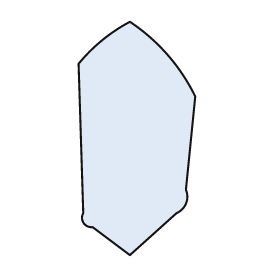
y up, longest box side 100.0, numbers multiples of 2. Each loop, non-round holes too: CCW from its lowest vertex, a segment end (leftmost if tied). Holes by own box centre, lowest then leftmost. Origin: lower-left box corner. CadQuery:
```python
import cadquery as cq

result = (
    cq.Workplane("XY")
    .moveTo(22.0, 0.0)
    .lineTo(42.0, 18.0)
    .threePointArc((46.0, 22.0), (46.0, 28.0))
    .lineTo(50.0, 68.0)
    .threePointArc((38.0, 86.0), (22.0, 100.0))
    .threePointArc((10.0, 92.0), (0.0, 82.0))
    .lineTo(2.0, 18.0)
    .threePointArc((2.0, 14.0), (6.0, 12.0))
    .close()
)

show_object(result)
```